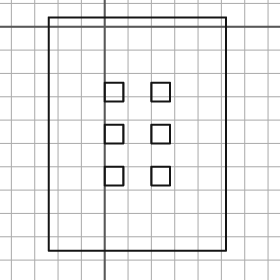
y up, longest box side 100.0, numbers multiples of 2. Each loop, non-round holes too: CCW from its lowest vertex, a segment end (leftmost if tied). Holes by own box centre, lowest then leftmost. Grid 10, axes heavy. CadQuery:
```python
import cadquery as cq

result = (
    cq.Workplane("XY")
    .moveTo(-24.0, -96.0)
    .lineTo(52.0, -96.0)
    .lineTo(52.0, 4.0)
    .lineTo(-24.0, 4.0)
    .close()
    .moveTo(0.0, -68.0)
    .lineTo(8.0, -68.0)
    .lineTo(8.0, -60.0)
    .lineTo(0.0, -60.0)
    .close()
    .moveTo(20.0, -68.0)
    .lineTo(28.0, -68.0)
    .lineTo(28.0, -60.0)
    .lineTo(20.0, -60.0)
    .close()
    .moveTo(0.0, -50.0)
    .lineTo(8.0, -50.0)
    .lineTo(8.0, -42.0)
    .lineTo(0.0, -42.0)
    .close()
    .moveTo(20.0, -50.0)
    .lineTo(28.0, -50.0)
    .lineTo(28.0, -42.0)
    .lineTo(20.0, -42.0)
    .close()
    .moveTo(0.0, -32.0)
    .lineTo(8.0, -32.0)
    .lineTo(8.0, -24.0)
    .lineTo(0.0, -24.0)
    .close()
    .moveTo(20.0, -32.0)
    .lineTo(28.0, -32.0)
    .lineTo(28.0, -24.0)
    .lineTo(20.0, -24.0)
    .close()
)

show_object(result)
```